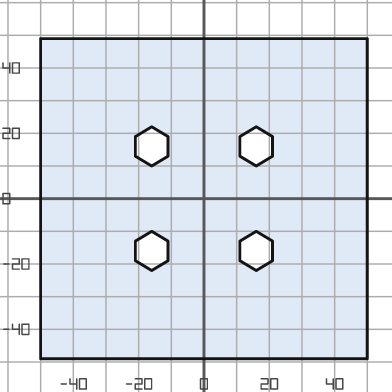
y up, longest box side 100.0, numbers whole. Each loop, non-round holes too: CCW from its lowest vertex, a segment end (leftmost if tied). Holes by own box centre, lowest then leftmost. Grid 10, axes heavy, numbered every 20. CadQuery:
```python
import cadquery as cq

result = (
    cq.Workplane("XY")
    .moveTo(-50.0, -49.0)
    .lineTo(50.0, -49.0)
    .lineTo(50.0, 49.0)
    .lineTo(-50.0, 49.0)
    .close()
    .moveTo(-16.0, -22.0)
    .lineTo(-11.0, -19.0)
    .lineTo(-11.0, -13.0)
    .lineTo(-16.0, -10.0)
    .lineTo(-21.0, -13.0)
    .lineTo(-21.0, -19.0)
    .close()
    .moveTo(16.0, -22.0)
    .lineTo(21.0, -19.0)
    .lineTo(21.0, -13.0)
    .lineTo(16.0, -10.0)
    .lineTo(11.0, -13.0)
    .lineTo(11.0, -19.0)
    .close()
    .moveTo(-16.0, 10.0)
    .lineTo(-11.0, 13.0)
    .lineTo(-11.0, 19.0)
    .lineTo(-16.0, 22.0)
    .lineTo(-21.0, 19.0)
    .lineTo(-21.0, 13.0)
    .close()
    .moveTo(16.0, 10.0)
    .lineTo(21.0, 13.0)
    .lineTo(21.0, 19.0)
    .lineTo(16.0, 22.0)
    .lineTo(11.0, 19.0)
    .lineTo(11.0, 13.0)
    .close()
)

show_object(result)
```